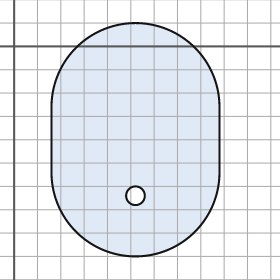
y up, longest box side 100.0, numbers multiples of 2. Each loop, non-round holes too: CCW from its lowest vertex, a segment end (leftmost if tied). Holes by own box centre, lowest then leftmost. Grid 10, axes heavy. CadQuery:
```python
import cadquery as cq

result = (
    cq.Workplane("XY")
    .moveTo(16.0, -54.0)
    .threePointArc((52.0, -90.0), (88.0, -54.0))
    .lineTo(88.0, -26.0)
    .threePointArc((52.0, 10.0), (16.0, -26.0))
    .close()
    .moveTo(52.0, -64.0)
    .circle(4.0)
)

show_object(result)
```